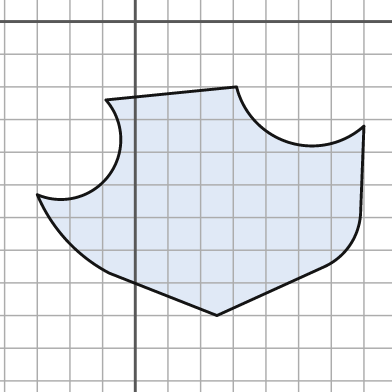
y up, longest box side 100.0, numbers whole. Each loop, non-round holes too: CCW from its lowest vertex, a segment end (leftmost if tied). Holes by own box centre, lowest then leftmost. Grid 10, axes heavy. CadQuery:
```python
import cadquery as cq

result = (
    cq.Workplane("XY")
    .moveTo(25.0, -90.0)
    .lineTo(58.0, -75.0)
    .threePointArc((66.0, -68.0), (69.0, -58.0))
    .lineTo(70.0, -32.0)
    .threePointArc((47.0, -37.0), (31.0, -20.0))
    .lineTo(-9.0, -24.0)
    .threePointArc((-8.0, -47.0), (-30.0, -53.0))
    .threePointArc((-21.0, -67.0), (-8.0, -77.0))
    .close()
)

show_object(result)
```